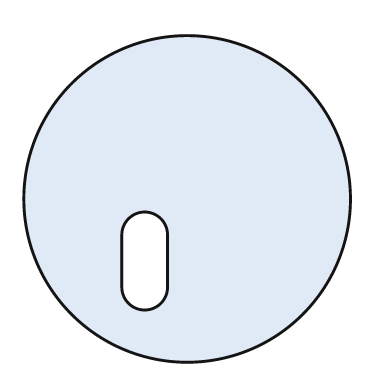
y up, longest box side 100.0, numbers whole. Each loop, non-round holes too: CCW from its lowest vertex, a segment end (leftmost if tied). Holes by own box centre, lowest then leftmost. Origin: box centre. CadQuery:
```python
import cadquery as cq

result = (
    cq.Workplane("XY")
    .moveTo(0.0, 0.0)
    .circle(50.0)
    .moveTo(-20.0, -27.0)
    .threePointArc((-13.0, -34.0), (-6.0, -27.0))
    .lineTo(-6.0, -11.0)
    .threePointArc((-13.0, -4.0), (-20.0, -11.0))
    .close()
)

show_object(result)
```